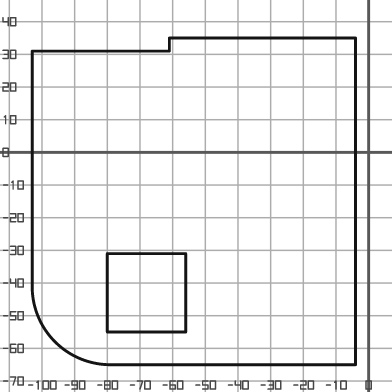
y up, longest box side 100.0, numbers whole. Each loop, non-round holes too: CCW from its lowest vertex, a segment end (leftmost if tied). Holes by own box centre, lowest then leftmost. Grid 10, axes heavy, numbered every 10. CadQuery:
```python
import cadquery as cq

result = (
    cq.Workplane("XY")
    .moveTo(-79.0, -65.0)
    .lineTo(-4.0, -65.0)
    .lineTo(-4.0, 35.0)
    .lineTo(-61.0, 35.0)
    .lineTo(-61.0, 31.0)
    .lineTo(-103.0, 31.0)
    .lineTo(-103.0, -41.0)
    .threePointArc((-96.0, -58.0), (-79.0, -65.0))
    .close()
    .moveTo(-80.0, -55.0)
    .lineTo(-56.0, -55.0)
    .lineTo(-56.0, -31.0)
    .lineTo(-80.0, -31.0)
    .close()
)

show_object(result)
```